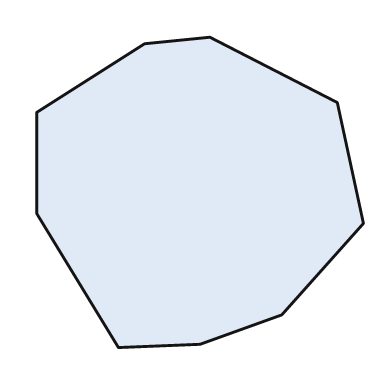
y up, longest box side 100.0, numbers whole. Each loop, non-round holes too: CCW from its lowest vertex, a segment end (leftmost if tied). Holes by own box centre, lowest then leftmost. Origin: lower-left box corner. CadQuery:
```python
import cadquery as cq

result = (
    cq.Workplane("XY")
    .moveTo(25.0, 0.0)
    .lineTo(50.0, 1.0)
    .lineTo(75.0, 10.0)
    .lineTo(100.0, 38.0)
    .lineTo(92.0, 75.0)
    .lineTo(53.0, 95.0)
    .lineTo(33.0, 93.0)
    .lineTo(0.0, 72.0)
    .lineTo(0.0, 41.0)
    .close()
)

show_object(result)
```